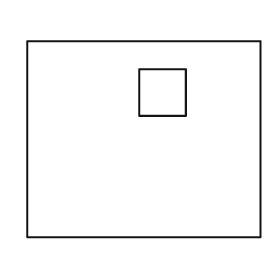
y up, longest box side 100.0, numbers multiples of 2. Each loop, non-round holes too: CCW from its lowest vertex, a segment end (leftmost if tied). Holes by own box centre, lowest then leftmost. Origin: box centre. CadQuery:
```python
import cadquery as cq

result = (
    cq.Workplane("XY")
    .moveTo(-50.0, -42.0)
    .lineTo(50.0, -42.0)
    .lineTo(50.0, 42.0)
    .lineTo(-50.0, 42.0)
    .close()
    .moveTo(-2.0, 10.0)
    .lineTo(18.0, 10.0)
    .lineTo(18.0, 30.0)
    .lineTo(-2.0, 30.0)
    .close()
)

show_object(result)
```